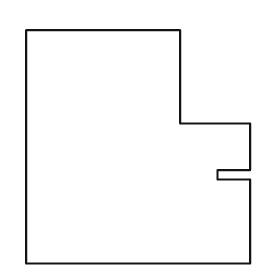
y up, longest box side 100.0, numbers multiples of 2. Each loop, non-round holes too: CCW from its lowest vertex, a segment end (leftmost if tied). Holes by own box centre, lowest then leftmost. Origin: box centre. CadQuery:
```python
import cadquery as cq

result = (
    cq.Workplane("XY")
    .moveTo(-48.0, -50.0)
    .lineTo(48.0, -50.0)
    .lineTo(48.0, -14.0)
    .lineTo(34.0, -14.0)
    .lineTo(34.0, -10.0)
    .lineTo(48.0, -10.0)
    .lineTo(48.0, 10.0)
    .lineTo(18.0, 10.0)
    .lineTo(18.0, 50.0)
    .lineTo(-48.0, 50.0)
    .close()
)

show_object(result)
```